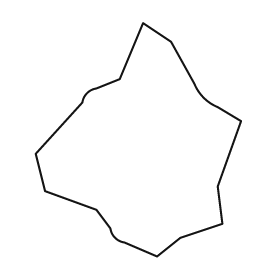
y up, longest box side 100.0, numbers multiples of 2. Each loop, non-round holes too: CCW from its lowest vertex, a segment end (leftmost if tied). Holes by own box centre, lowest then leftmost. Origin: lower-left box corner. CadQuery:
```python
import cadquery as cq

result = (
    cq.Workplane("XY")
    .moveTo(52.0, 0.0)
    .lineTo(62.0, 8.0)
    .lineTo(80.0, 14.0)
    .lineTo(78.0, 30.0)
    .lineTo(88.0, 58.0)
    .lineTo(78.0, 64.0)
    .threePointArc((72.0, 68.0), (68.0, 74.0))
    .lineTo(58.0, 92.0)
    .lineTo(46.0, 100.0)
    .lineTo(36.0, 76.0)
    .lineTo(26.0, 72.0)
    .threePointArc((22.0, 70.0), (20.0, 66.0))
    .lineTo(0.0, 44.0)
    .lineTo(4.0, 28.0)
    .lineTo(26.0, 20.0)
    .lineTo(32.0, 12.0)
    .threePointArc((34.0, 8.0), (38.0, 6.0))
    .close()
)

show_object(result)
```